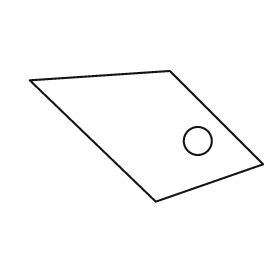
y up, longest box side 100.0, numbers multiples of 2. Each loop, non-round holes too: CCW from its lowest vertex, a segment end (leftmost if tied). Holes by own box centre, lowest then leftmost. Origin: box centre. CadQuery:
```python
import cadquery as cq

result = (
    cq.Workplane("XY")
    .moveTo(4.0, -28.0)
    .lineTo(50.0, -12.0)
    .lineTo(10.0, 28.0)
    .lineTo(-50.0, 24.0)
    .close()
    .moveTo(22.0, -2.0)
    .circle(6.0)
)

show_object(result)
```